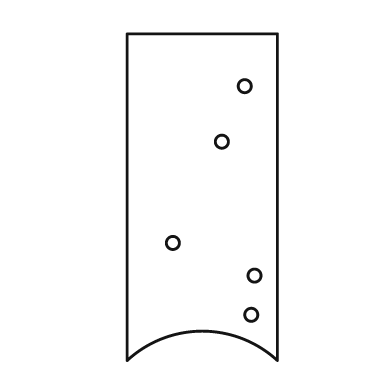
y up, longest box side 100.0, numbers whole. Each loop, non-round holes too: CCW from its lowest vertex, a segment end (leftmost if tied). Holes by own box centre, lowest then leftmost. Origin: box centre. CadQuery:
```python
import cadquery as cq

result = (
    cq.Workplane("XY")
    .moveTo(-23.0, -50.0)
    .threePointArc((0.0, -41.0), (23.0, -50.0))
    .lineTo(23.0, 50.0)
    .lineTo(-23.0, 50.0)
    .close()
    .moveTo(15.0, -36.0)
    .circle(2.0)
    .moveTo(16.0, -24.0)
    .circle(2.0)
    .moveTo(-9.0, -14.0)
    .circle(2.0)
    .moveTo(6.0, 17.0)
    .circle(2.0)
    .moveTo(13.0, 34.0)
    .circle(2.0)
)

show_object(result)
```